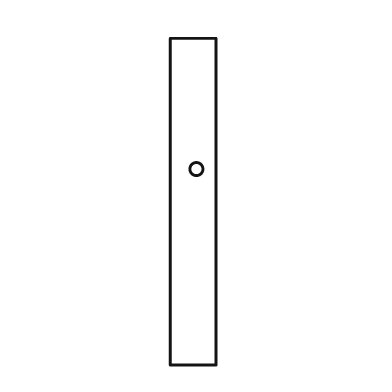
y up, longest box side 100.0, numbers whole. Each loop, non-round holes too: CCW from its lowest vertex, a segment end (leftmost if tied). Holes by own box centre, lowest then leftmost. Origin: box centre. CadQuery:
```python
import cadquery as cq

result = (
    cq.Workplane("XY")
    .moveTo(-7.0, -50.0)
    .lineTo(7.0, -50.0)
    .lineTo(7.0, 50.0)
    .lineTo(-7.0, 50.0)
    .close()
    .moveTo(1.0, 10.0)
    .circle(2.0)
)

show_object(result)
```